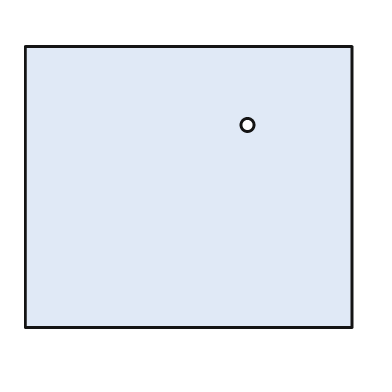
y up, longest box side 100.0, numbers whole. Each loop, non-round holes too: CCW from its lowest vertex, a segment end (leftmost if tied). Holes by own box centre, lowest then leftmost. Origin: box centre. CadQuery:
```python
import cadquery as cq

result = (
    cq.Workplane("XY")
    .moveTo(-50.0, -43.0)
    .lineTo(50.0, -43.0)
    .lineTo(50.0, 43.0)
    .lineTo(-50.0, 43.0)
    .close()
    .moveTo(18.0, 19.0)
    .circle(2.0)
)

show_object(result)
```